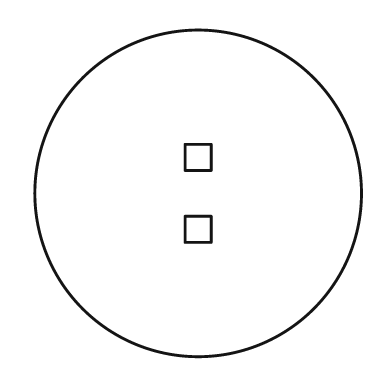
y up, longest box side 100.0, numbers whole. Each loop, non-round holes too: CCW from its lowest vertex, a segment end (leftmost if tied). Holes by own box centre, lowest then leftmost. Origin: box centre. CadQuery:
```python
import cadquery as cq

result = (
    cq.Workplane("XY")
    .moveTo(0.0, 0.0)
    .circle(50.0)
    .moveTo(-4.0, -15.0)
    .lineTo(4.0, -15.0)
    .lineTo(4.0, -7.0)
    .lineTo(-4.0, -7.0)
    .close()
    .moveTo(-4.0, 7.0)
    .lineTo(4.0, 7.0)
    .lineTo(4.0, 15.0)
    .lineTo(-4.0, 15.0)
    .close()
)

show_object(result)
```